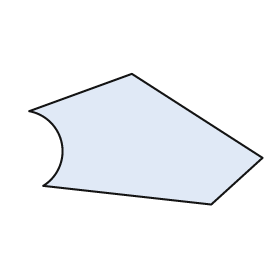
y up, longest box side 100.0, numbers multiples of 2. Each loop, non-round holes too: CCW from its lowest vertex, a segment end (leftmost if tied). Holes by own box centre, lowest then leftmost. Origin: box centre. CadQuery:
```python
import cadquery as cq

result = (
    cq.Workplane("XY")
    .moveTo(28.0, -28.0)
    .lineTo(50.0, -8.0)
    .lineTo(-6.0, 28.0)
    .lineTo(-50.0, 12.0)
    .threePointArc((-36.0, -2.0), (-44.0, -20.0))
    .close()
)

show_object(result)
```